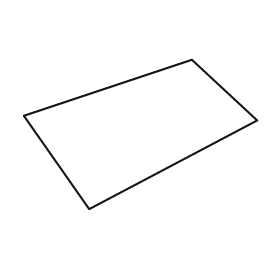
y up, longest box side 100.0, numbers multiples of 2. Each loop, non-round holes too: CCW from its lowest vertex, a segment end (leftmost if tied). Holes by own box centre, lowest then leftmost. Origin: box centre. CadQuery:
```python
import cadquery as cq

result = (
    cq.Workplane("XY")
    .moveTo(-22.0, -32.0)
    .lineTo(50.0, 6.0)
    .lineTo(22.0, 32.0)
    .lineTo(-50.0, 8.0)
    .close()
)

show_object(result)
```